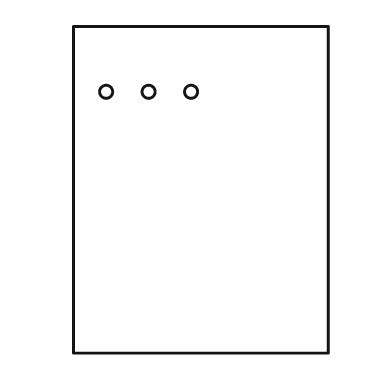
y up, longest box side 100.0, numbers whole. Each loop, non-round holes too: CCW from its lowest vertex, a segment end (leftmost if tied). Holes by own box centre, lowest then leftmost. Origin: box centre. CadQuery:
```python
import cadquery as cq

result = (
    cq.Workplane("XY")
    .moveTo(-39.0, -50.0)
    .lineTo(39.0, -50.0)
    .lineTo(39.0, 50.0)
    .lineTo(-39.0, 50.0)
    .close()
    .moveTo(-29.0, 30.0)
    .circle(2.0)
    .moveTo(-16.0, 30.0)
    .circle(2.0)
    .moveTo(-3.0, 30.0)
    .circle(2.0)
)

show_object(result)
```